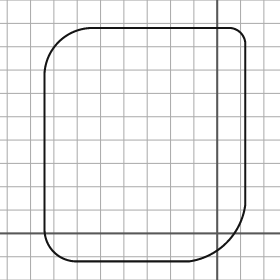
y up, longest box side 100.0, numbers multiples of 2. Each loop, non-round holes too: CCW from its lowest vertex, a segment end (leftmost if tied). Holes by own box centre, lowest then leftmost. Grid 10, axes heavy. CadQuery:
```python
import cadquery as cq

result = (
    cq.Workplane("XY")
    .moveTo(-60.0, -12.0)
    .lineTo(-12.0, -12.0)
    .threePointArc((4.0, -4.0), (12.0, 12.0))
    .lineTo(12.0, 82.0)
    .threePointArc((10.0, 86.0), (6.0, 88.0))
    .lineTo(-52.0, 88.0)
    .threePointArc((-68.0, 82.0), (-74.0, 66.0))
    .lineTo(-74.0, 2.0)
    .threePointArc((-70.0, -8.0), (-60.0, -12.0))
    .close()
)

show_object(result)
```